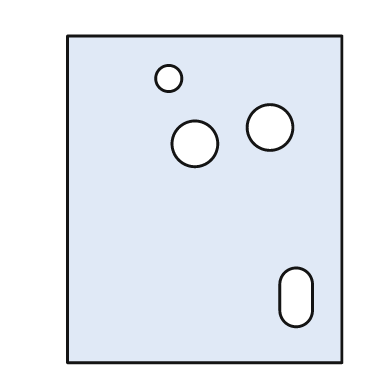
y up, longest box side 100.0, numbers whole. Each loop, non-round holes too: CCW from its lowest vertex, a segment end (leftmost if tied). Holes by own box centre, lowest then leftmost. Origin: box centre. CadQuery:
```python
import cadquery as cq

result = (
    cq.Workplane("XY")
    .moveTo(-42.0, -50.0)
    .lineTo(42.0, -50.0)
    .lineTo(42.0, 50.0)
    .lineTo(-42.0, 50.0)
    .close()
    .moveTo(23.0, -34.0)
    .threePointArc((28.0, -39.0), (33.0, -34.0))
    .lineTo(33.0, -26.0)
    .threePointArc((28.0, -21.0), (23.0, -26.0))
    .close()
    .moveTo(-3.0, 17.0)
    .circle(7.0)
    .moveTo(20.0, 22.0)
    .circle(7.0)
    .moveTo(-11.0, 37.0)
    .circle(4.0)
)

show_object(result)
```